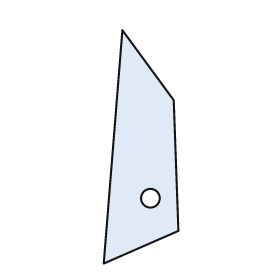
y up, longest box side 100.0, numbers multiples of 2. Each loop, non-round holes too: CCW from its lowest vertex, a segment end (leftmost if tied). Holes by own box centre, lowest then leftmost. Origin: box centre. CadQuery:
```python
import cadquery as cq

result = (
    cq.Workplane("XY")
    .moveTo(-16.0, -50.0)
    .lineTo(16.0, -36.0)
    .lineTo(14.0, 20.0)
    .lineTo(-8.0, 50.0)
    .close()
    .moveTo(4.0, -22.0)
    .circle(4.0)
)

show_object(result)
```